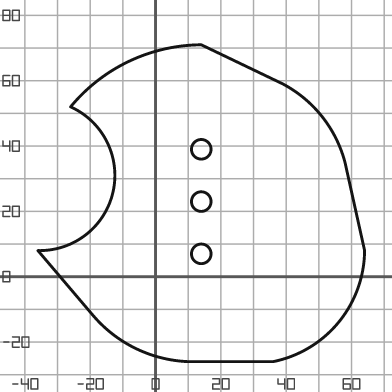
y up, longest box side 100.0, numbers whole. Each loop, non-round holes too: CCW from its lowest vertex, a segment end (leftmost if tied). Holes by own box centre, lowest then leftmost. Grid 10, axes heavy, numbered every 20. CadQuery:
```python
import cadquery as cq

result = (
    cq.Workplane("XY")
    .moveTo(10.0, -26.0)
    .lineTo(36.0, -26.0)
    .threePointArc((56.0, -14.0), (64.0, 8.0))
    .lineTo(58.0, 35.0)
    .threePointArc((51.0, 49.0), (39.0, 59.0))
    .lineTo(14.0, 71.0)
    .threePointArc((-8.0, 66.0), (-26.0, 52.0))
    .threePointArc((-13.0, 26.0), (-36.0, 8.0))
    .lineTo(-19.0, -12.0)
    .threePointArc((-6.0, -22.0), (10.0, -26.0))
    .close()
    .moveTo(14.0, 7.0)
    .circle(3.0)
    .moveTo(14.0, 23.0)
    .circle(3.0)
    .moveTo(14.0, 39.0)
    .circle(3.0)
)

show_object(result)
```